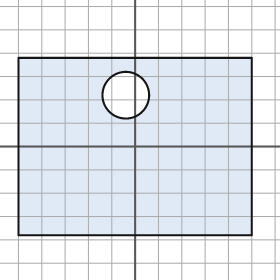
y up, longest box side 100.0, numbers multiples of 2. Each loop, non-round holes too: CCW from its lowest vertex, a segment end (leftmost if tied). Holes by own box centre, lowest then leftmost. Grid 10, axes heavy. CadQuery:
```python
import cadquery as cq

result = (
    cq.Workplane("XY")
    .moveTo(-50.0, -38.0)
    .lineTo(50.0, -38.0)
    .lineTo(50.0, 38.0)
    .lineTo(-50.0, 38.0)
    .close()
    .moveTo(-4.0, 22.0)
    .circle(10.0)
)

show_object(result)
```